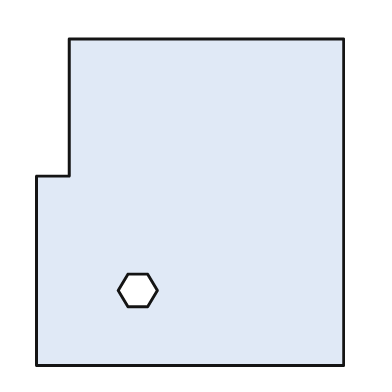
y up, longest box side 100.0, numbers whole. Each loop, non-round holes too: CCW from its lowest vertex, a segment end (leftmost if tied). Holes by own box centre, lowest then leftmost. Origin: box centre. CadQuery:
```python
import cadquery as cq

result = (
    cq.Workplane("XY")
    .moveTo(-47.0, -50.0)
    .lineTo(47.0, -50.0)
    .lineTo(47.0, 50.0)
    .lineTo(-37.0, 50.0)
    .lineTo(-37.0, 8.0)
    .lineTo(-47.0, 8.0)
    .close()
    .moveTo(-19.0, -32.0)
    .lineTo(-13.0, -32.0)
    .lineTo(-10.0, -27.0)
    .lineTo(-13.0, -22.0)
    .lineTo(-19.0, -22.0)
    .lineTo(-22.0, -27.0)
    .close()
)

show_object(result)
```